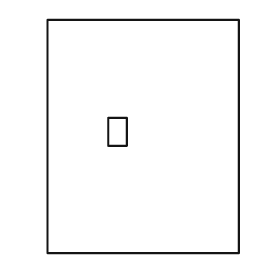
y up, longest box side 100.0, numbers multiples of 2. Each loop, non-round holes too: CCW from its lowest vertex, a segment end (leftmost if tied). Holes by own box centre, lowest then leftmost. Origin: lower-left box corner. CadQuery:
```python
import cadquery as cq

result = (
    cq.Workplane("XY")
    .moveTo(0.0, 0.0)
    .lineTo(82.0, 0.0)
    .lineTo(82.0, 100.0)
    .lineTo(0.0, 100.0)
    .close()
    .moveTo(26.0, 46.0)
    .lineTo(34.0, 46.0)
    .lineTo(34.0, 58.0)
    .lineTo(26.0, 58.0)
    .close()
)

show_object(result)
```